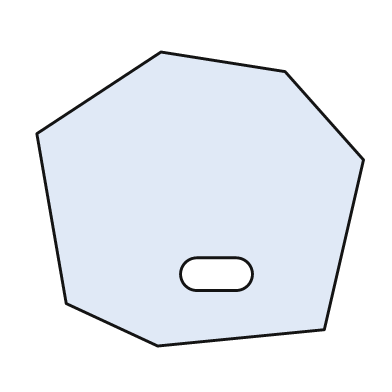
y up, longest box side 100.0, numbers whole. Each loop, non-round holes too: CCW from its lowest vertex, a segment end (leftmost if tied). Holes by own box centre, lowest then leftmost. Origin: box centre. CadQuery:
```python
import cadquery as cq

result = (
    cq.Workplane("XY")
    .moveTo(-13.0, -45.0)
    .lineTo(38.0, -40.0)
    .lineTo(50.0, 12.0)
    .lineTo(26.0, 39.0)
    .lineTo(-12.0, 45.0)
    .lineTo(-50.0, 20.0)
    .lineTo(-41.0, -32.0)
    .close()
    .moveTo(-1.0, -28.0)
    .lineTo(11.0, -28.0)
    .threePointArc((16.0, -23.0), (11.0, -18.0))
    .lineTo(-1.0, -18.0)
    .threePointArc((-6.0, -23.0), (-1.0, -28.0))
    .close()
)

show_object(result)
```